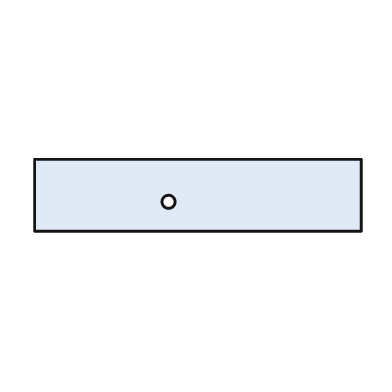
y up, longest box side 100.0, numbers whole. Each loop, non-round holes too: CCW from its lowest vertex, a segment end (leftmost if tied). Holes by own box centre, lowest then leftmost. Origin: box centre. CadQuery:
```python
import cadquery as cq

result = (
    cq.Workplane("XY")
    .moveTo(-50.0, -11.0)
    .lineTo(50.0, -11.0)
    .lineTo(50.0, 11.0)
    .lineTo(-50.0, 11.0)
    .close()
    .moveTo(-9.0, -2.0)
    .circle(2.0)
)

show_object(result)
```